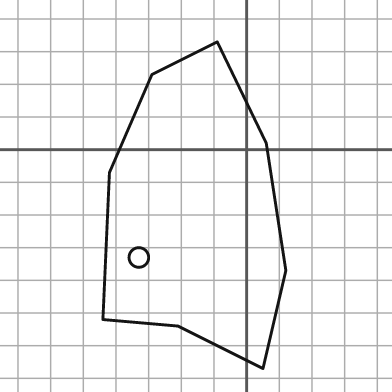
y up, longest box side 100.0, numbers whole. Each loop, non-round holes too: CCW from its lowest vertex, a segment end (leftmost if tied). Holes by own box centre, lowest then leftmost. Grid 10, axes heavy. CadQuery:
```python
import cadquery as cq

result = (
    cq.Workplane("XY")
    .moveTo(5.0, -67.0)
    .lineTo(12.0, -37.0)
    .lineTo(6.0, 2.0)
    .lineTo(-9.0, 33.0)
    .lineTo(-29.0, 23.0)
    .lineTo(-42.0, -7.0)
    .lineTo(-44.0, -52.0)
    .lineTo(-21.0, -54.0)
    .close()
    .moveTo(-33.0, -33.0)
    .circle(3.0)
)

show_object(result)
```